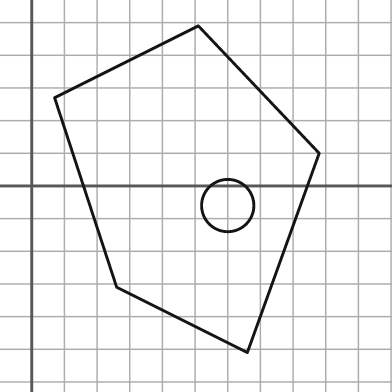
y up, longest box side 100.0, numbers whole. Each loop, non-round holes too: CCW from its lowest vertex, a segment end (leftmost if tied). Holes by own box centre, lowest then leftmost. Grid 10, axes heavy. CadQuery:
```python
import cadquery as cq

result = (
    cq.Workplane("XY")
    .moveTo(66.0, -51.0)
    .lineTo(88.0, 10.0)
    .lineTo(51.0, 49.0)
    .lineTo(7.0, 27.0)
    .lineTo(26.0, -31.0)
    .close()
    .moveTo(60.0, -6.0)
    .circle(8.0)
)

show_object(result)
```